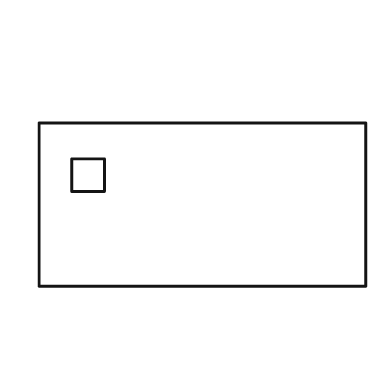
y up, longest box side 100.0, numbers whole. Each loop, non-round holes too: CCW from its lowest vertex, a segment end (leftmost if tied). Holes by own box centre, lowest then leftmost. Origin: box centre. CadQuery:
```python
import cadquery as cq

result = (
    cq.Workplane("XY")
    .moveTo(-50.0, -25.0)
    .lineTo(50.0, -25.0)
    .lineTo(50.0, 25.0)
    .lineTo(-50.0, 25.0)
    .close()
    .moveTo(-40.0, 4.0)
    .lineTo(-30.0, 4.0)
    .lineTo(-30.0, 14.0)
    .lineTo(-40.0, 14.0)
    .close()
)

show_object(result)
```